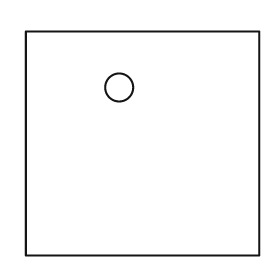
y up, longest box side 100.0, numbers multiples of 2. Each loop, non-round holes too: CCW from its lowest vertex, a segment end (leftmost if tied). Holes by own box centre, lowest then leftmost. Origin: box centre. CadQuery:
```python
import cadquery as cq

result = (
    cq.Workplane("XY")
    .moveTo(-50.0, -48.0)
    .lineTo(50.0, -48.0)
    .lineTo(50.0, 48.0)
    .lineTo(-50.0, 48.0)
    .close()
    .moveTo(-10.0, 24.0)
    .circle(6.0)
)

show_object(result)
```